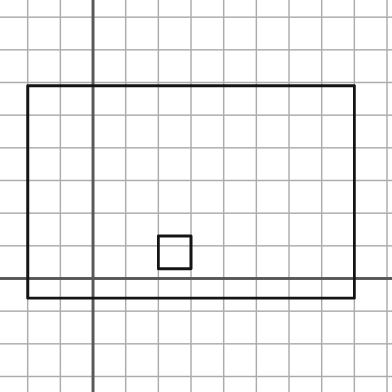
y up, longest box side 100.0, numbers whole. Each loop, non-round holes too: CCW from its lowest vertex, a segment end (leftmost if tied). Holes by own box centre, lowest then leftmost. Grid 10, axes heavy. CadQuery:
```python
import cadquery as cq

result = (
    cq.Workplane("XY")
    .moveTo(-20.0, -6.0)
    .lineTo(80.0, -6.0)
    .lineTo(80.0, 59.0)
    .lineTo(-20.0, 59.0)
    .close()
    .moveTo(20.0, 3.0)
    .lineTo(30.0, 3.0)
    .lineTo(30.0, 13.0)
    .lineTo(20.0, 13.0)
    .close()
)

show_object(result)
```